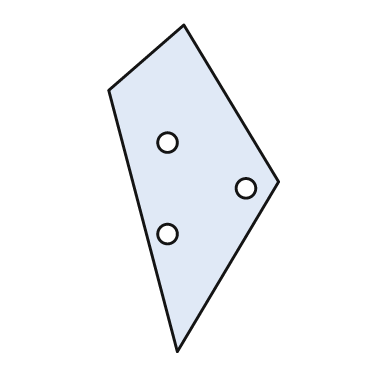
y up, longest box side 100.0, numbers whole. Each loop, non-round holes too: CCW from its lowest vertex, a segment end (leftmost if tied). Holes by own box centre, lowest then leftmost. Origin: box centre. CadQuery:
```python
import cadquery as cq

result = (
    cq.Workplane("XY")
    .moveTo(-5.0, -50.0)
    .lineTo(26.0, 2.0)
    .lineTo(-3.0, 50.0)
    .lineTo(-26.0, 30.0)
    .close()
    .moveTo(-8.0, -14.0)
    .circle(3.0)
    .moveTo(16.0, 0.0)
    .circle(3.0)
    .moveTo(-8.0, 14.0)
    .circle(3.0)
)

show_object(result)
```